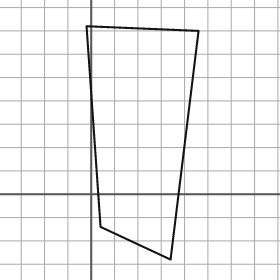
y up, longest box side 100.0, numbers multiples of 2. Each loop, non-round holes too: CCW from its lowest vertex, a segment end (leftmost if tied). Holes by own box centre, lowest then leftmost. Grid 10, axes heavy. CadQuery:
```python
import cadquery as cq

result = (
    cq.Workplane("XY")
    .moveTo(34.0, -28.0)
    .lineTo(46.0, 70.0)
    .lineTo(-2.0, 72.0)
    .lineTo(4.0, -14.0)
    .close()
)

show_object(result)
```